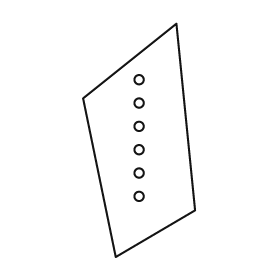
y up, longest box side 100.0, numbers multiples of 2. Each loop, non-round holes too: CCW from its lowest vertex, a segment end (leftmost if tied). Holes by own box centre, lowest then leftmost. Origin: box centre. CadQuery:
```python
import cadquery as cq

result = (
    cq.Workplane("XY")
    .moveTo(-10.0, -50.0)
    .lineTo(24.0, -30.0)
    .lineTo(16.0, 50.0)
    .lineTo(-24.0, 18.0)
    .close()
    .moveTo(0.0, -24.0)
    .circle(2.0)
    .moveTo(0.0, -14.0)
    .circle(2.0)
    .moveTo(0.0, -4.0)
    .circle(2.0)
    .moveTo(0.0, 6.0)
    .circle(2.0)
    .moveTo(0.0, 16.0)
    .circle(2.0)
    .moveTo(0.0, 26.0)
    .circle(2.0)
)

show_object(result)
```